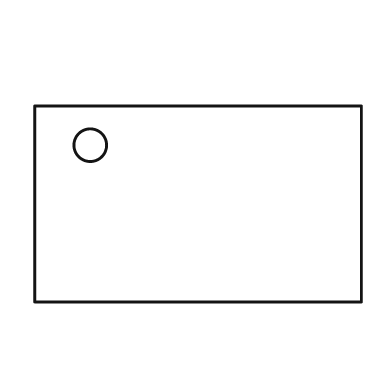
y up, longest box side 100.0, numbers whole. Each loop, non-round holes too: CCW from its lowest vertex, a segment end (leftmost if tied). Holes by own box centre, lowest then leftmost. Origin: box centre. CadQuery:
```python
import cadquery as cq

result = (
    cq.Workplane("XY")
    .moveTo(-50.0, -30.0)
    .lineTo(50.0, -30.0)
    .lineTo(50.0, 30.0)
    .lineTo(-50.0, 30.0)
    .close()
    .moveTo(-33.0, 18.0)
    .circle(5.0)
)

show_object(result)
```